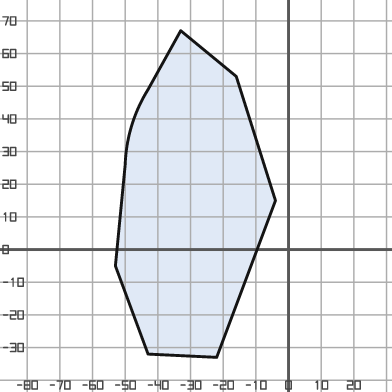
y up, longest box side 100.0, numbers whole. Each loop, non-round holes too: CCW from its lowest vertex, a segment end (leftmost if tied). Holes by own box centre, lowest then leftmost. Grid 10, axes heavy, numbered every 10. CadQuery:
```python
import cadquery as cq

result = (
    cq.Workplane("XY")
    .moveTo(-22.0, -33.0)
    .lineTo(-4.0, 15.0)
    .lineTo(-16.0, 53.0)
    .lineTo(-33.0, 67.0)
    .lineTo(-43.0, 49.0)
    .threePointArc((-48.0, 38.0), (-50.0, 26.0))
    .lineTo(-53.0, -5.0)
    .lineTo(-43.0, -32.0)
    .close()
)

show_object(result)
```